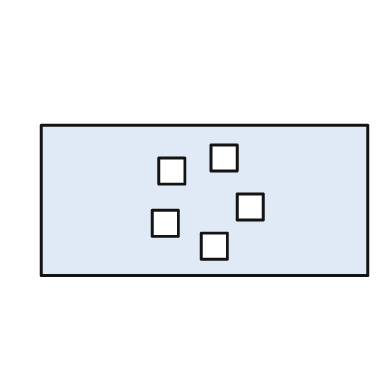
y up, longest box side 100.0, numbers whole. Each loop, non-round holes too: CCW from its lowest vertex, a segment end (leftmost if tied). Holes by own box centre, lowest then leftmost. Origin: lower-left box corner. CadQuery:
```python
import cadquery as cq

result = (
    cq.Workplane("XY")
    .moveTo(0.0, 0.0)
    .lineTo(100.0, 0.0)
    .lineTo(100.0, 46.0)
    .lineTo(0.0, 46.0)
    .close()
    .moveTo(49.0, 5.0)
    .lineTo(57.0, 5.0)
    .lineTo(57.0, 13.0)
    .lineTo(49.0, 13.0)
    .close()
    .moveTo(34.0, 12.0)
    .lineTo(42.0, 12.0)
    .lineTo(42.0, 20.0)
    .lineTo(34.0, 20.0)
    .close()
    .moveTo(60.0, 17.0)
    .lineTo(68.0, 17.0)
    .lineTo(68.0, 25.0)
    .lineTo(60.0, 25.0)
    .close()
    .moveTo(36.0, 28.0)
    .lineTo(44.0, 28.0)
    .lineTo(44.0, 36.0)
    .lineTo(36.0, 36.0)
    .close()
    .moveTo(52.0, 32.0)
    .lineTo(60.0, 32.0)
    .lineTo(60.0, 40.0)
    .lineTo(52.0, 40.0)
    .close()
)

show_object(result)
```